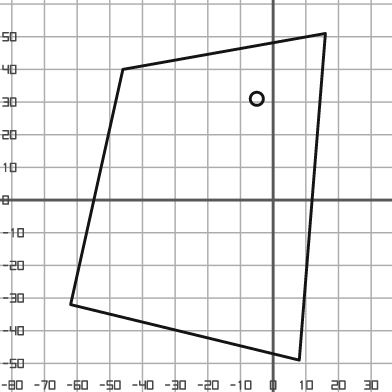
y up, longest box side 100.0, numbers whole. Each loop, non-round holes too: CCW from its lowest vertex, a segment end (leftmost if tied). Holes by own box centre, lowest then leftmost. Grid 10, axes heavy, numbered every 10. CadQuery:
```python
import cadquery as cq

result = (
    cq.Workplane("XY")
    .moveTo(8.0, -49.0)
    .lineTo(16.0, 51.0)
    .lineTo(-46.0, 40.0)
    .lineTo(-62.0, -32.0)
    .close()
    .moveTo(-5.0, 31.0)
    .circle(2.0)
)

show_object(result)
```